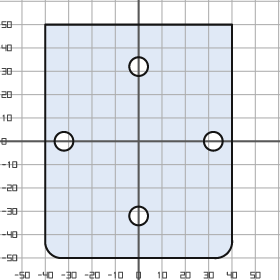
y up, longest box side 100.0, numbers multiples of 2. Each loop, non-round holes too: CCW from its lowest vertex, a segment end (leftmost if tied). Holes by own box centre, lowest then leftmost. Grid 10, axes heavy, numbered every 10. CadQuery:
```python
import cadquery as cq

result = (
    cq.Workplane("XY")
    .moveTo(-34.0, -50.0)
    .lineTo(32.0, -50.0)
    .threePointArc((38.0, -48.0), (40.0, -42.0))
    .lineTo(40.0, 50.0)
    .lineTo(-40.0, 50.0)
    .lineTo(-40.0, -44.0)
    .threePointArc((-38.0, -48.0), (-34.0, -50.0))
    .close()
    .moveTo(0.0, -32.0)
    .circle(4.0)
    .moveTo(-32.0, 0.0)
    .circle(4.0)
    .moveTo(32.0, 0.0)
    .circle(4.0)
    .moveTo(0.0, 32.0)
    .circle(4.0)
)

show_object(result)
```